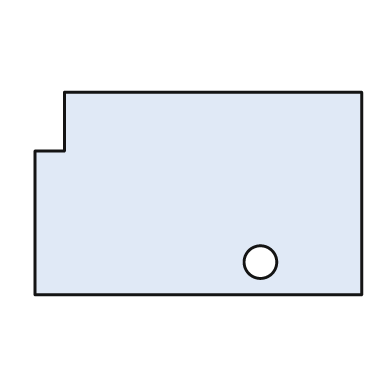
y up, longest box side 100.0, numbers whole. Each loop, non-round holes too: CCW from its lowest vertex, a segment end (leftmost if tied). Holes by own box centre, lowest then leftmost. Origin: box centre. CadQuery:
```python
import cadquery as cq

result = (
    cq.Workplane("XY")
    .moveTo(-50.0, -31.0)
    .lineTo(50.0, -31.0)
    .lineTo(50.0, 31.0)
    .lineTo(-41.0, 31.0)
    .lineTo(-41.0, 13.0)
    .lineTo(-50.0, 13.0)
    .close()
    .moveTo(19.0, -21.0)
    .circle(5.0)
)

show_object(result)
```